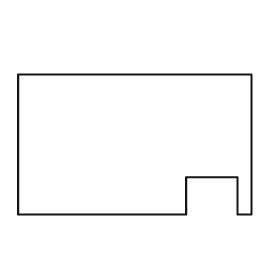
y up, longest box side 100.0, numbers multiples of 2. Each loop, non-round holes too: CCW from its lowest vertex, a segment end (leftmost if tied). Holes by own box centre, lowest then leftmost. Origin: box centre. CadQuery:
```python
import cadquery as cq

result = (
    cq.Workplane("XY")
    .moveTo(-50.0, -30.0)
    .lineTo(22.0, -30.0)
    .lineTo(22.0, -14.0)
    .lineTo(44.0, -14.0)
    .lineTo(44.0, -30.0)
    .lineTo(50.0, -30.0)
    .lineTo(50.0, 30.0)
    .lineTo(-50.0, 30.0)
    .close()
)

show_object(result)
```